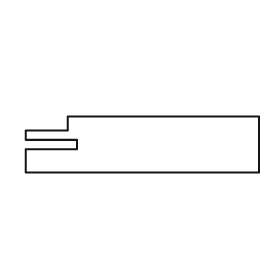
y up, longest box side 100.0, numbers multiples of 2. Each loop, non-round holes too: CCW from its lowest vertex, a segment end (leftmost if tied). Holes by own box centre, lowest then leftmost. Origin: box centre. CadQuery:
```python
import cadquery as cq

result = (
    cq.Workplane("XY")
    .moveTo(-50.0, -12.0)
    .lineTo(50.0, -12.0)
    .lineTo(50.0, 12.0)
    .lineTo(-32.0, 12.0)
    .lineTo(-32.0, 6.0)
    .lineTo(-50.0, 6.0)
    .lineTo(-50.0, 2.0)
    .lineTo(-28.0, 2.0)
    .lineTo(-28.0, -2.0)
    .lineTo(-50.0, -2.0)
    .close()
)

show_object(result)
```